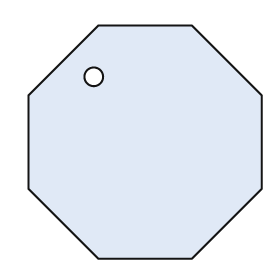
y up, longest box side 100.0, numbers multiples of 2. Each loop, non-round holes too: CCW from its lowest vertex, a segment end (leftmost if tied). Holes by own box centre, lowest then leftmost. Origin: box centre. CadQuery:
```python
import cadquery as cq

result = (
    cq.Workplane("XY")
    .moveTo(-20.0, -50.0)
    .lineTo(20.0, -50.0)
    .lineTo(50.0, -20.0)
    .lineTo(50.0, 20.0)
    .lineTo(20.0, 50.0)
    .lineTo(-20.0, 50.0)
    .lineTo(-50.0, 20.0)
    .lineTo(-50.0, -20.0)
    .close()
    .moveTo(-22.0, 28.0)
    .circle(4.0)
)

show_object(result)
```